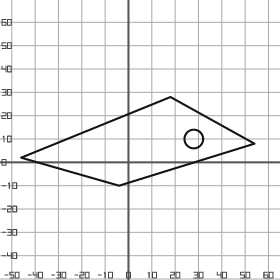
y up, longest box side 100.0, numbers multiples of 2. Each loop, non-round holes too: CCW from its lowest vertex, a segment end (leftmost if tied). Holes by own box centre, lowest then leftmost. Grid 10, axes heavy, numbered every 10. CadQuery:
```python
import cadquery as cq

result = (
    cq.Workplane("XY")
    .moveTo(-4.0, -10.0)
    .lineTo(54.0, 8.0)
    .lineTo(18.0, 28.0)
    .lineTo(-46.0, 2.0)
    .close()
    .moveTo(28.0, 10.0)
    .circle(4.0)
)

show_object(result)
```